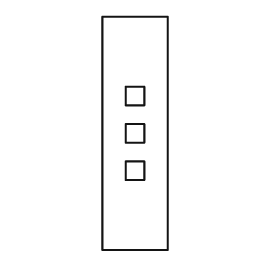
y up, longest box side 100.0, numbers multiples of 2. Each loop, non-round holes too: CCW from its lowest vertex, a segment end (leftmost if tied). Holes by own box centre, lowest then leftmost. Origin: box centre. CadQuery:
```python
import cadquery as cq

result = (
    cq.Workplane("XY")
    .moveTo(-14.0, -50.0)
    .lineTo(14.0, -50.0)
    .lineTo(14.0, 50.0)
    .lineTo(-14.0, 50.0)
    .close()
    .moveTo(-4.0, -20.0)
    .lineTo(4.0, -20.0)
    .lineTo(4.0, -12.0)
    .lineTo(-4.0, -12.0)
    .close()
    .moveTo(-4.0, -4.0)
    .lineTo(4.0, -4.0)
    .lineTo(4.0, 4.0)
    .lineTo(-4.0, 4.0)
    .close()
    .moveTo(-4.0, 12.0)
    .lineTo(4.0, 12.0)
    .lineTo(4.0, 20.0)
    .lineTo(-4.0, 20.0)
    .close()
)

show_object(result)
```